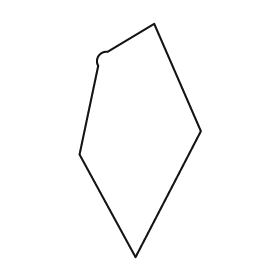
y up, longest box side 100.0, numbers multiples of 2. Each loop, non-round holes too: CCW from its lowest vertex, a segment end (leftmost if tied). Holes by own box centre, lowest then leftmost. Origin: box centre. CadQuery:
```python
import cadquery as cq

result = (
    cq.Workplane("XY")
    .moveTo(-2.0, -50.0)
    .lineTo(26.0, 4.0)
    .lineTo(6.0, 50.0)
    .lineTo(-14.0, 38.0)
    .threePointArc((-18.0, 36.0), (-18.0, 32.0))
    .lineTo(-26.0, -6.0)
    .close()
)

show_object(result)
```